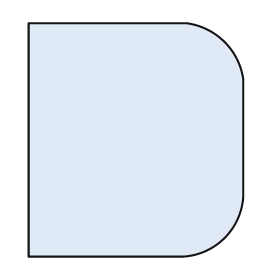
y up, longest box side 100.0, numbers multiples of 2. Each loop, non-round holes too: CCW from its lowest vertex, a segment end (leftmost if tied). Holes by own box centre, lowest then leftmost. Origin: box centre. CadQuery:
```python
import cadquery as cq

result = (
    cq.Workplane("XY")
    .moveTo(-46.0, -50.0)
    .lineTo(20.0, -50.0)
    .threePointArc((38.0, -42.0), (46.0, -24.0))
    .lineTo(46.0, 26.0)
    .threePointArc((38.0, 42.0), (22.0, 50.0))
    .lineTo(-46.0, 50.0)
    .close()
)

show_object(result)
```